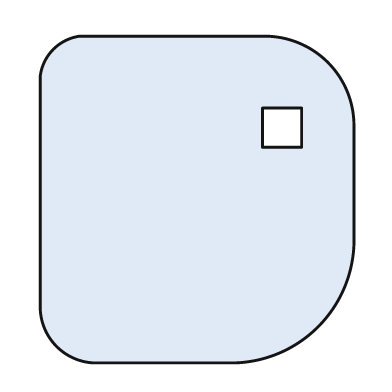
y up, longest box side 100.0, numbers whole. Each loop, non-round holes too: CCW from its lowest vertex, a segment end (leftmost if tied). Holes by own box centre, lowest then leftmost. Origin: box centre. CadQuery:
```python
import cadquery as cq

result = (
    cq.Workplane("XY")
    .moveTo(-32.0, -50.0)
    .lineTo(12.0, -50.0)
    .threePointArc((37.0, -39.0), (48.0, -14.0))
    .lineTo(48.0, 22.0)
    .threePointArc((40.0, 42.0), (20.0, 50.0))
    .lineTo(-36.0, 50.0)
    .threePointArc((-44.0, 46.0), (-48.0, 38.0))
    .lineTo(-48.0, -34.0)
    .threePointArc((-43.0, -45.0), (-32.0, -50.0))
    .close()
    .moveTo(20.0, 16.0)
    .lineTo(32.0, 16.0)
    .lineTo(32.0, 28.0)
    .lineTo(20.0, 28.0)
    .close()
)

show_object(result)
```